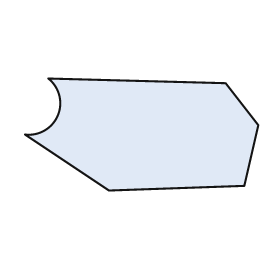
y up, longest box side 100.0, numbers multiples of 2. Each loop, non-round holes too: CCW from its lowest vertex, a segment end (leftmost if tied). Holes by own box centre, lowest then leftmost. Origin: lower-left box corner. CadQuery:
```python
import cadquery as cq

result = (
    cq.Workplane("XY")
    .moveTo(36.0, 0.0)
    .lineTo(94.0, 2.0)
    .lineTo(100.0, 28.0)
    .lineTo(86.0, 46.0)
    .lineTo(10.0, 48.0)
    .threePointArc((14.0, 32.0), (0.0, 24.0))
    .close()
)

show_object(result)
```